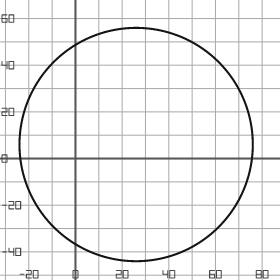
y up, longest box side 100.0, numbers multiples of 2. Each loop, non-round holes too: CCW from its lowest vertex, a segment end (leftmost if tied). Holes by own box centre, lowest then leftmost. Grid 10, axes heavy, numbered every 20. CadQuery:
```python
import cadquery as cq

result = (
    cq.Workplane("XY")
    .moveTo(26.0, 6.0)
    .circle(50.0)
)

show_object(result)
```